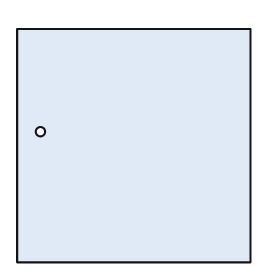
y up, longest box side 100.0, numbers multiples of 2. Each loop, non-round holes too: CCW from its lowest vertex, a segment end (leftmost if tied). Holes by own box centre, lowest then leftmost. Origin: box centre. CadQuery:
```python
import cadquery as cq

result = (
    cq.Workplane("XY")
    .moveTo(-50.0, -50.0)
    .lineTo(50.0, -50.0)
    .lineTo(50.0, 50.0)
    .lineTo(-50.0, 50.0)
    .close()
    .moveTo(-40.0, 6.0)
    .circle(2.0)
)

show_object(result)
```